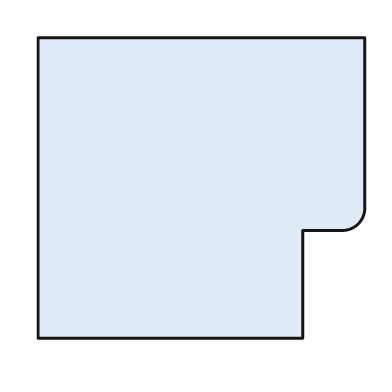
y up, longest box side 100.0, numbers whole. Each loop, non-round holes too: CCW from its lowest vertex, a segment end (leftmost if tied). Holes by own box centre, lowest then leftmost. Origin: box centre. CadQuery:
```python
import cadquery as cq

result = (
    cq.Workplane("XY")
    .moveTo(-50.0, -46.0)
    .lineTo(31.0, -46.0)
    .lineTo(31.0, -13.0)
    .lineTo(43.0, -13.0)
    .threePointArc((48.0, -11.0), (50.0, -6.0))
    .lineTo(50.0, 46.0)
    .lineTo(-50.0, 46.0)
    .close()
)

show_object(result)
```